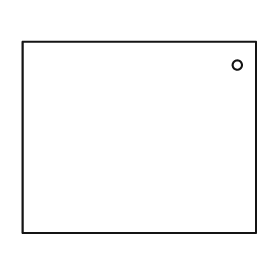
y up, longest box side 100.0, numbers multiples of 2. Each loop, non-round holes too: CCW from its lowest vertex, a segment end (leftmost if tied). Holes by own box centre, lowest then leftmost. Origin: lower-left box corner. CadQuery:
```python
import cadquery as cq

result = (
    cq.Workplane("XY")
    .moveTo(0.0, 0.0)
    .lineTo(100.0, 0.0)
    .lineTo(100.0, 82.0)
    .lineTo(0.0, 82.0)
    .close()
    .moveTo(92.0, 72.0)
    .circle(2.0)
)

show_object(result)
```